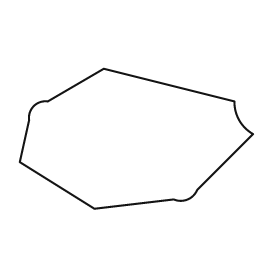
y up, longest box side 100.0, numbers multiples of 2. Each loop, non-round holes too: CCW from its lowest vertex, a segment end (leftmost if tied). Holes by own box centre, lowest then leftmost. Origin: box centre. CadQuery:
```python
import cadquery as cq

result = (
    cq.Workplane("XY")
    .moveTo(-18.0, -30.0)
    .lineTo(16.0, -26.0)
    .threePointArc((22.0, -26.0), (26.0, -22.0))
    .lineTo(50.0, 2.0)
    .threePointArc((44.0, 8.0), (42.0, 16.0))
    .lineTo(-14.0, 30.0)
    .lineTo(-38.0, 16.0)
    .threePointArc((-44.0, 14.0), (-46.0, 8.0))
    .lineTo(-50.0, -10.0)
    .close()
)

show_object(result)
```